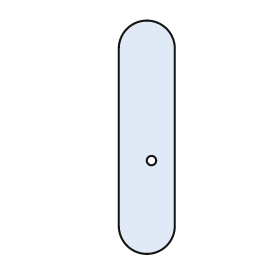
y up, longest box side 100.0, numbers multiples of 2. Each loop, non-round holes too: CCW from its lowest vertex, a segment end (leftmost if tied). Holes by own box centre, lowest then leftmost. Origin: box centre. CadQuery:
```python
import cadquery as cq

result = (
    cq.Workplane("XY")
    .moveTo(-12.0, -38.0)
    .threePointArc((0.0, -50.0), (12.0, -38.0))
    .lineTo(12.0, 38.0)
    .threePointArc((0.0, 50.0), (-12.0, 38.0))
    .close()
    .moveTo(2.0, -10.0)
    .circle(2.0)
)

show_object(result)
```